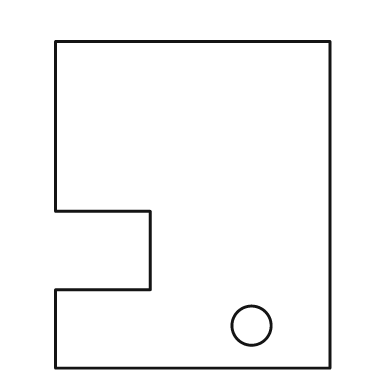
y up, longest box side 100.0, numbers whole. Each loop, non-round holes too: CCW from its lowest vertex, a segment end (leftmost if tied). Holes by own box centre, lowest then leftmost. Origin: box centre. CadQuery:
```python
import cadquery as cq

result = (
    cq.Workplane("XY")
    .moveTo(-42.0, -50.0)
    .lineTo(42.0, -50.0)
    .lineTo(42.0, 50.0)
    .lineTo(-42.0, 50.0)
    .lineTo(-42.0, -2.0)
    .lineTo(-13.0, -2.0)
    .lineTo(-13.0, -26.0)
    .lineTo(-42.0, -26.0)
    .close()
    .moveTo(18.0, -37.0)
    .circle(6.0)
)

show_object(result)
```